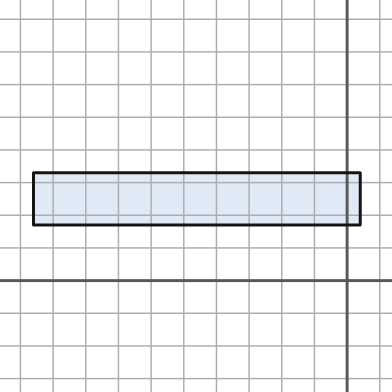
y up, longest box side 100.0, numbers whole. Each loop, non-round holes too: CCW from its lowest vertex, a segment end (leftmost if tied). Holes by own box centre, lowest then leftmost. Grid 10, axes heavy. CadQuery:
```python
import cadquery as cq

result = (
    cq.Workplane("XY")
    .moveTo(-96.0, 17.0)
    .lineTo(4.0, 17.0)
    .lineTo(4.0, 33.0)
    .lineTo(-96.0, 33.0)
    .close()
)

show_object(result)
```